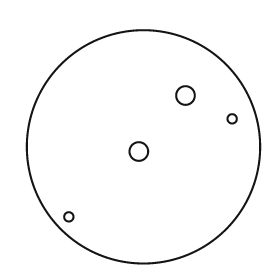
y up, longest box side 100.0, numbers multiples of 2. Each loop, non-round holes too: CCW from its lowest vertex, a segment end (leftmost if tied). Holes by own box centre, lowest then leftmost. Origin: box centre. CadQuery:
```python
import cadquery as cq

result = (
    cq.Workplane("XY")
    .moveTo(0.0, 0.0)
    .circle(50.0)
    .moveTo(-32.0, -30.0)
    .circle(2.0)
    .moveTo(-2.0, -2.0)
    .circle(4.0)
    .moveTo(38.0, 12.0)
    .circle(2.0)
    .moveTo(18.0, 22.0)
    .circle(4.0)
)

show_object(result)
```